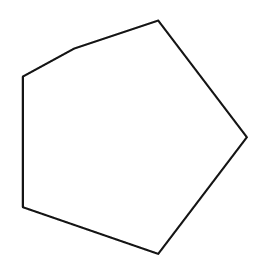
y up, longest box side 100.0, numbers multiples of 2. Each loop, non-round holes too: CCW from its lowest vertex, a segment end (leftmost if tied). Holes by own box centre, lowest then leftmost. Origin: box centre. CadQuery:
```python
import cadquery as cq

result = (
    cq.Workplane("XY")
    .moveTo(10.0, -50.0)
    .lineTo(48.0, 0.0)
    .lineTo(10.0, 50.0)
    .lineTo(-26.0, 38.0)
    .lineTo(-48.0, 26.0)
    .lineTo(-48.0, -30.0)
    .close()
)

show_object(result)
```